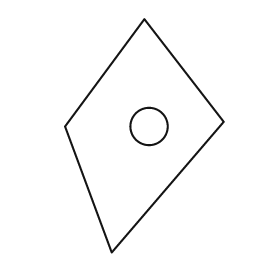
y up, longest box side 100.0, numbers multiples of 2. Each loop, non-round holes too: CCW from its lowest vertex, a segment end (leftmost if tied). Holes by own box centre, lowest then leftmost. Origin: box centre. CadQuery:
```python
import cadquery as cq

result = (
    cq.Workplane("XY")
    .moveTo(-14.0, -50.0)
    .lineTo(34.0, 6.0)
    .lineTo(0.0, 50.0)
    .lineTo(-34.0, 4.0)
    .close()
    .moveTo(2.0, 4.0)
    .circle(8.0)
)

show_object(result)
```